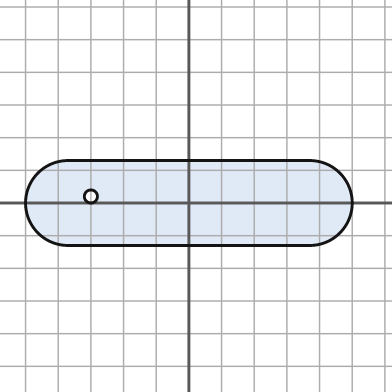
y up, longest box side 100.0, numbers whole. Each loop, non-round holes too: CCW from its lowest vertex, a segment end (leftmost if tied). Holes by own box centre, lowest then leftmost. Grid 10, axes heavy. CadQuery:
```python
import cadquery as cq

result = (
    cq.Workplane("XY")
    .moveTo(-37.0, -13.0)
    .lineTo(37.0, -13.0)
    .threePointArc((50.0, 0.0), (37.0, 13.0))
    .lineTo(-37.0, 13.0)
    .threePointArc((-50.0, 0.0), (-37.0, -13.0))
    .close()
    .moveTo(-30.0, 2.0)
    .circle(2.0)
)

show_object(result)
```